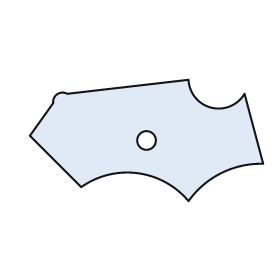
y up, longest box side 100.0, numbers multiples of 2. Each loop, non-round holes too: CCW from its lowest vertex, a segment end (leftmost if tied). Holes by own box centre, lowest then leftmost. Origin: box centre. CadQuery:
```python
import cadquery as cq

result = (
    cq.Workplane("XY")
    .moveTo(18.0, -26.0)
    .threePointArc((32.0, -14.0), (50.0, -10.0))
    .lineTo(42.0, 20.0)
    .threePointArc((28.0, 14.0), (18.0, 26.0))
    .lineTo(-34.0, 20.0)
    .threePointArc((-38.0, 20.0), (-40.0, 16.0))
    .lineTo(-50.0, 2.0)
    .lineTo(-28.0, -20.0)
    .threePointArc((-4.0, -14.0), (18.0, -26.0))
    .close()
    .moveTo(0.0, 0.0)
    .circle(4.0)
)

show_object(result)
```